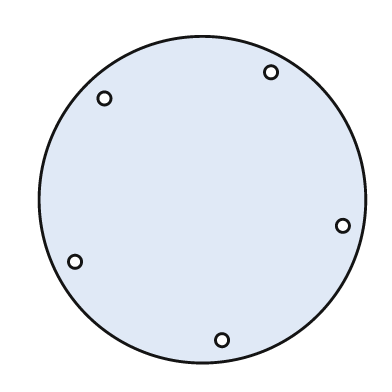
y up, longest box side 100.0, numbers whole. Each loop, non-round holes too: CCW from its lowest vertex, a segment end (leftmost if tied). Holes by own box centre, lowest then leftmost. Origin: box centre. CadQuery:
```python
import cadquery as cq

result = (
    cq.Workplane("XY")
    .moveTo(0.0, 0.0)
    .circle(50.0)
    .moveTo(6.0, -43.0)
    .circle(2.0)
    .moveTo(-39.0, -19.0)
    .circle(2.0)
    .moveTo(43.0, -8.0)
    .circle(2.0)
    .moveTo(-30.0, 31.0)
    .circle(2.0)
    .moveTo(21.0, 39.0)
    .circle(2.0)
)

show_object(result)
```